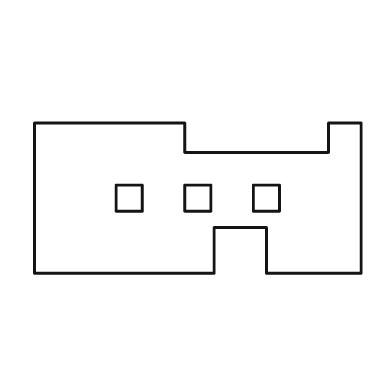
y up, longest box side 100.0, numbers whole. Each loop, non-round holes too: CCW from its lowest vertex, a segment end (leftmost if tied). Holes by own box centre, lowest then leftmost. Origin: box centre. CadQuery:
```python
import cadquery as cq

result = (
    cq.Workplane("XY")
    .moveTo(-50.0, -23.0)
    .lineTo(5.0, -23.0)
    .lineTo(5.0, -9.0)
    .lineTo(21.0, -9.0)
    .lineTo(21.0, -23.0)
    .lineTo(50.0, -23.0)
    .lineTo(50.0, 23.0)
    .lineTo(40.0, 23.0)
    .lineTo(40.0, 14.0)
    .lineTo(-4.0, 14.0)
    .lineTo(-4.0, 23.0)
    .lineTo(-50.0, 23.0)
    .close()
    .moveTo(-25.0, -4.0)
    .lineTo(-17.0, -4.0)
    .lineTo(-17.0, 4.0)
    .lineTo(-25.0, 4.0)
    .close()
    .moveTo(-4.0, -4.0)
    .lineTo(4.0, -4.0)
    .lineTo(4.0, 4.0)
    .lineTo(-4.0, 4.0)
    .close()
    .moveTo(17.0, -4.0)
    .lineTo(25.0, -4.0)
    .lineTo(25.0, 4.0)
    .lineTo(17.0, 4.0)
    .close()
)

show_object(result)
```